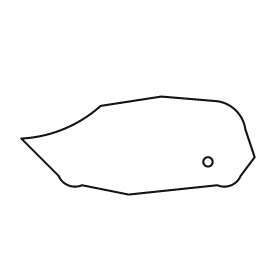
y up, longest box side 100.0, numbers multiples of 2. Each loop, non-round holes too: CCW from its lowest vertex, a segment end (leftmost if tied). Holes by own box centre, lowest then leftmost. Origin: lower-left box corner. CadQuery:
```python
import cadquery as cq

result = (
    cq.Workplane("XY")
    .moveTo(46.0, 0.0)
    .lineTo(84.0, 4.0)
    .threePointArc((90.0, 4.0), (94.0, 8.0))
    .lineTo(100.0, 16.0)
    .lineTo(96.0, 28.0)
    .threePointArc((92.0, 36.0), (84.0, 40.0))
    .lineTo(60.0, 42.0)
    .lineTo(34.0, 38.0)
    .threePointArc((18.0, 28.0), (0.0, 24.0))
    .lineTo(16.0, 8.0)
    .threePointArc((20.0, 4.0), (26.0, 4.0))
    .close()
    .moveTo(80.0, 14.0)
    .circle(2.0)
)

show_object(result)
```